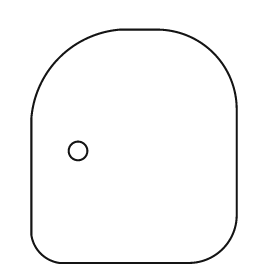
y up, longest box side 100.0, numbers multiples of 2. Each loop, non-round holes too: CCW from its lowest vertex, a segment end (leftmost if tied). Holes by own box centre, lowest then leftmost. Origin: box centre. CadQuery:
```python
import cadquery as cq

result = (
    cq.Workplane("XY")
    .moveTo(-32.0, -50.0)
    .lineTo(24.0, -50.0)
    .threePointArc((38.0, -44.0), (44.0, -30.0))
    .lineTo(44.0, 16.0)
    .threePointArc((34.0, 40.0), (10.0, 50.0))
    .lineTo(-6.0, 50.0)
    .threePointArc((-32.0, 38.0), (-44.0, 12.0))
    .lineTo(-44.0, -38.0)
    .threePointArc((-40.0, -46.0), (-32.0, -50.0))
    .close()
    .moveTo(-24.0, -2.0)
    .circle(4.0)
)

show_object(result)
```